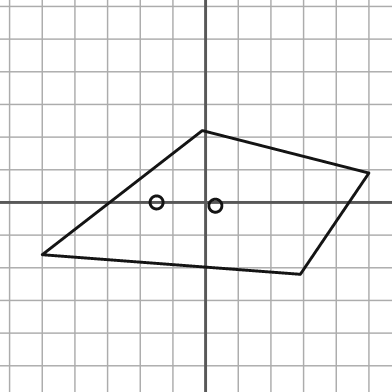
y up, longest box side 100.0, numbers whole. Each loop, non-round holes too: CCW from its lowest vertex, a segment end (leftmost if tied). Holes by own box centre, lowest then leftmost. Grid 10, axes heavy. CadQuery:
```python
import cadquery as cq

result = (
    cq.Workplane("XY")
    .moveTo(29.0, -22.0)
    .lineTo(50.0, 9.0)
    .lineTo(-1.0, 22.0)
    .lineTo(-50.0, -16.0)
    .close()
    .moveTo(3.0, -1.0)
    .circle(2.0)
    .moveTo(-15.0, 0.0)
    .circle(2.0)
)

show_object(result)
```